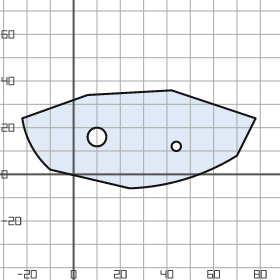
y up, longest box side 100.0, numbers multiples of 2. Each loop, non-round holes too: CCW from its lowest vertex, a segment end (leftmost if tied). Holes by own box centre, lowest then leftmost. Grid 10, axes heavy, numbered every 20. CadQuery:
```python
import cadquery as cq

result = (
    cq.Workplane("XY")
    .moveTo(24.0, -6.0)
    .threePointArc((48.0, -2.0), (70.0, 8.0))
    .lineTo(78.0, 24.0)
    .lineTo(42.0, 36.0)
    .lineTo(6.0, 34.0)
    .lineTo(-22.0, 24.0)
    .threePointArc((-18.0, 12.0), (-10.0, 2.0))
    .close()
    .moveTo(44.0, 12.0)
    .circle(2.0)
    .moveTo(10.0, 16.0)
    .circle(4.0)
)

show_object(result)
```